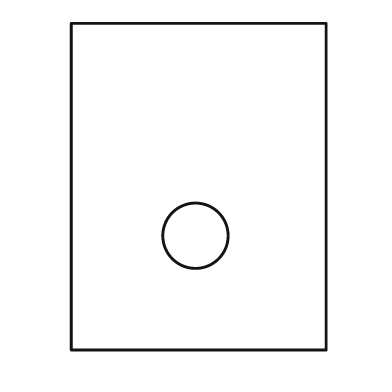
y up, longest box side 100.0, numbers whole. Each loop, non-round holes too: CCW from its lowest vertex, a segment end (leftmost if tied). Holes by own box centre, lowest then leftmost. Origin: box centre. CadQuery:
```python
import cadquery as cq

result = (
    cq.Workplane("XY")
    .moveTo(-39.0, -50.0)
    .lineTo(39.0, -50.0)
    .lineTo(39.0, 50.0)
    .lineTo(-39.0, 50.0)
    .close()
    .moveTo(-1.0, -15.0)
    .circle(10.0)
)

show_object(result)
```